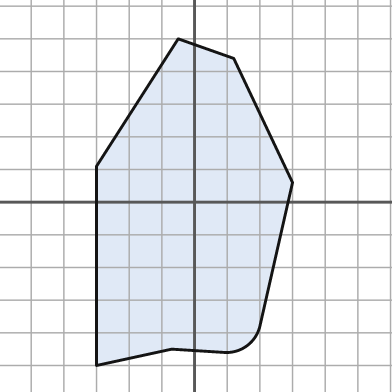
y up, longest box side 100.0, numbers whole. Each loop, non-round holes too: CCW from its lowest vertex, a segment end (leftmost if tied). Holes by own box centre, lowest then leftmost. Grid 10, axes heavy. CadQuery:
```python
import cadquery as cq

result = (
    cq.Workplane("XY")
    .moveTo(-30.0, -50.0)
    .lineTo(-7.0, -45.0)
    .lineTo(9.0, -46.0)
    .threePointArc((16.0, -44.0), (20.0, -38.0))
    .lineTo(30.0, 6.0)
    .lineTo(12.0, 44.0)
    .lineTo(-5.0, 50.0)
    .lineTo(-30.0, 11.0)
    .close()
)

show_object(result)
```